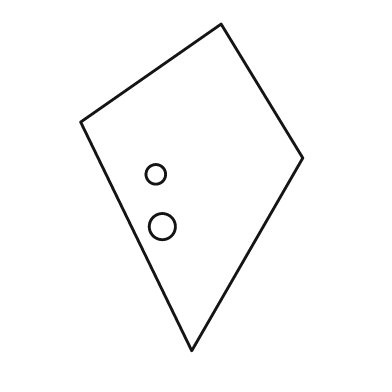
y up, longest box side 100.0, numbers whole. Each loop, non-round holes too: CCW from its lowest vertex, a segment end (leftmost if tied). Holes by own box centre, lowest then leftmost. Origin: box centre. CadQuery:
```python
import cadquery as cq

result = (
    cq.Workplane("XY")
    .moveTo(0.0, -50.0)
    .lineTo(34.0, 9.0)
    .lineTo(9.0, 50.0)
    .lineTo(-34.0, 20.0)
    .close()
    .moveTo(-9.0, -12.0)
    .circle(4.0)
    .moveTo(-11.0, 4.0)
    .circle(3.0)
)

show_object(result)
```